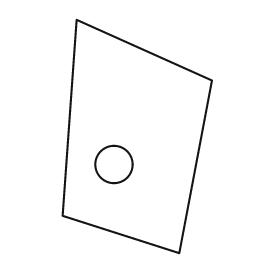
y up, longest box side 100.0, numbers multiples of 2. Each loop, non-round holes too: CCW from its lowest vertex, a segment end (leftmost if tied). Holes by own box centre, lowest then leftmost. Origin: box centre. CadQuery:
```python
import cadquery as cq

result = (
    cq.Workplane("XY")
    .moveTo(18.0, -50.0)
    .lineTo(32.0, 24.0)
    .lineTo(-26.0, 50.0)
    .lineTo(-32.0, -34.0)
    .close()
    .moveTo(-10.0, -12.0)
    .circle(8.0)
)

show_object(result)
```